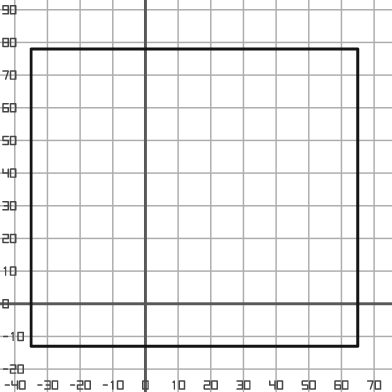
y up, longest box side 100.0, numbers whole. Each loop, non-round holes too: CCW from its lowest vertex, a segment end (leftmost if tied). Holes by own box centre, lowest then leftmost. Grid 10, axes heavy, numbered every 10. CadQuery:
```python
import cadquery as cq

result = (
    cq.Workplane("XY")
    .moveTo(-35.0, -13.0)
    .lineTo(65.0, -13.0)
    .lineTo(65.0, 78.0)
    .lineTo(-35.0, 78.0)
    .close()
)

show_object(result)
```